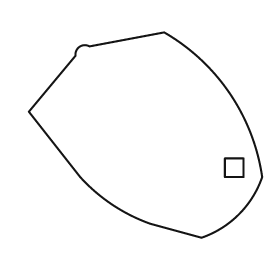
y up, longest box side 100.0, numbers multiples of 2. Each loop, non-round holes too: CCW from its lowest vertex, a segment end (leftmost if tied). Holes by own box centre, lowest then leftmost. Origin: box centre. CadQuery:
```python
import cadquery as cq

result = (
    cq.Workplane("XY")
    .moveTo(24.0, -44.0)
    .threePointArc((40.0, -34.0), (50.0, -18.0))
    .threePointArc((36.0, 18.0), (8.0, 44.0))
    .lineTo(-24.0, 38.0)
    .threePointArc((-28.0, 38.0), (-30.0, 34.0))
    .lineTo(-50.0, 10.0)
    .lineTo(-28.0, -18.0)
    .threePointArc((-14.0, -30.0), (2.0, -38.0))
    .close()
    .moveTo(34.0, -18.0)
    .lineTo(42.0, -18.0)
    .lineTo(42.0, -10.0)
    .lineTo(34.0, -10.0)
    .close()
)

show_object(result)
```